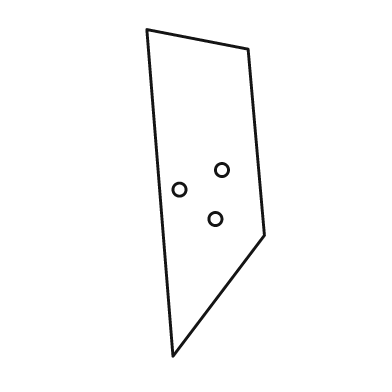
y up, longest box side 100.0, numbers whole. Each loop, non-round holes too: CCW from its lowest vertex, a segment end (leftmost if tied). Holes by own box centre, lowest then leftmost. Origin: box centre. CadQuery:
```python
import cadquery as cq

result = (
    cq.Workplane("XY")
    .moveTo(-10.0, -50.0)
    .lineTo(18.0, -13.0)
    .lineTo(13.0, 44.0)
    .lineTo(-18.0, 50.0)
    .close()
    .moveTo(3.0, -8.0)
    .circle(2.0)
    .moveTo(-8.0, 1.0)
    .circle(2.0)
    .moveTo(5.0, 7.0)
    .circle(2.0)
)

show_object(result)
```